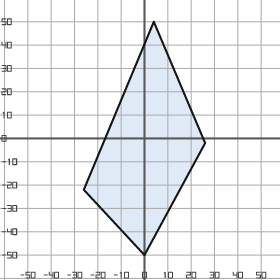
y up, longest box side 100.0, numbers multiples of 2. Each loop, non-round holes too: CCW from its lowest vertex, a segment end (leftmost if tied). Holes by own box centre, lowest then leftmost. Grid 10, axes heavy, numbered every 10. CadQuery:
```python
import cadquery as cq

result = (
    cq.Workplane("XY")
    .moveTo(0.0, -50.0)
    .lineTo(26.0, -2.0)
    .lineTo(4.0, 50.0)
    .lineTo(-26.0, -22.0)
    .close()
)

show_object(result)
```